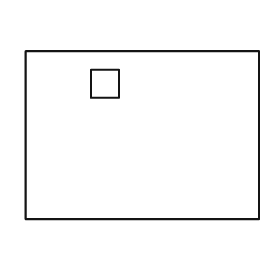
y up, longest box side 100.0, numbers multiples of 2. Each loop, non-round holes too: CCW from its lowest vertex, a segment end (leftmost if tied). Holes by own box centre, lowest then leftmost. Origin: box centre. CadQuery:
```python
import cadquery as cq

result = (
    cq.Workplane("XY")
    .moveTo(-50.0, -36.0)
    .lineTo(50.0, -36.0)
    .lineTo(50.0, 36.0)
    .lineTo(-50.0, 36.0)
    .close()
    .moveTo(-22.0, 16.0)
    .lineTo(-10.0, 16.0)
    .lineTo(-10.0, 28.0)
    .lineTo(-22.0, 28.0)
    .close()
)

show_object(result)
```